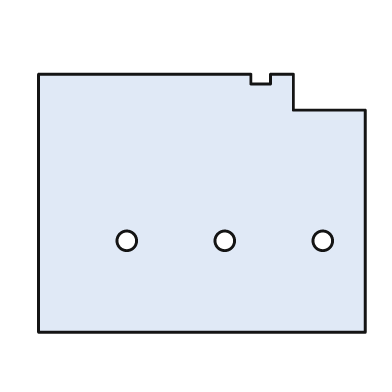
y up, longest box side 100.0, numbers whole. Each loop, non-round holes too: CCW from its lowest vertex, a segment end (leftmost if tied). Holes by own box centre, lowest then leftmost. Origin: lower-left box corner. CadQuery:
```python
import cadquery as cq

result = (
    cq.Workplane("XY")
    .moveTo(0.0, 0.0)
    .lineTo(100.0, 0.0)
    .lineTo(100.0, 68.0)
    .lineTo(78.0, 68.0)
    .lineTo(78.0, 79.0)
    .lineTo(71.0, 79.0)
    .lineTo(71.0, 76.0)
    .lineTo(65.0, 76.0)
    .lineTo(65.0, 79.0)
    .lineTo(0.0, 79.0)
    .close()
    .moveTo(27.0, 28.0)
    .circle(3.0)
    .moveTo(57.0, 28.0)
    .circle(3.0)
    .moveTo(87.0, 28.0)
    .circle(3.0)
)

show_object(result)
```